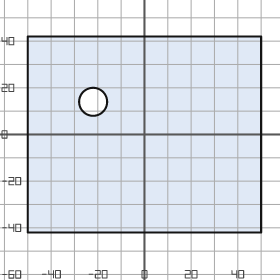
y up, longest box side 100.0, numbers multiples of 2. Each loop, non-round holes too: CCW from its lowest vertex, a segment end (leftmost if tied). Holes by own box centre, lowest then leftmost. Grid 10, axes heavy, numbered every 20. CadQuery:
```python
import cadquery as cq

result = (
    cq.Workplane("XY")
    .moveTo(-50.0, -42.0)
    .lineTo(50.0, -42.0)
    .lineTo(50.0, 42.0)
    .lineTo(-50.0, 42.0)
    .close()
    .moveTo(-22.0, 14.0)
    .circle(6.0)
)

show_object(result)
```